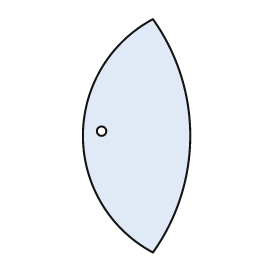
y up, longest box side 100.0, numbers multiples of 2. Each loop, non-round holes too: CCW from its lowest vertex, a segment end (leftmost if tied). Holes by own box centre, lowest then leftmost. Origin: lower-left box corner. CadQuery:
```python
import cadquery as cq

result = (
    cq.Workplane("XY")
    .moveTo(30.0, 0.0)
    .threePointArc((46.0, 50.0), (30.0, 100.0))
    .threePointArc((0.0, 50.0), (30.0, 0.0))
    .close()
    .moveTo(8.0, 52.0)
    .circle(2.0)
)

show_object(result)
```